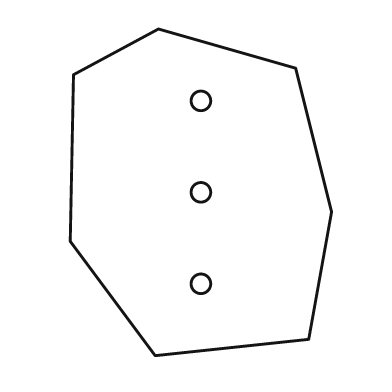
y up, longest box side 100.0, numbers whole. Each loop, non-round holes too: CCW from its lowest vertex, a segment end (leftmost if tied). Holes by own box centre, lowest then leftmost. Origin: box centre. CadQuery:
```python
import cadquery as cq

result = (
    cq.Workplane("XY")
    .moveTo(-14.0, -50.0)
    .lineTo(33.0, -45.0)
    .lineTo(40.0, -6.0)
    .lineTo(29.0, 38.0)
    .lineTo(-13.0, 50.0)
    .lineTo(-39.0, 36.0)
    .lineTo(-40.0, -15.0)
    .close()
    .moveTo(0.0, -28.0)
    .circle(3.0)
    .moveTo(0.0, 0.0)
    .circle(3.0)
    .moveTo(0.0, 28.0)
    .circle(3.0)
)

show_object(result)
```